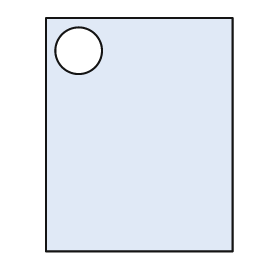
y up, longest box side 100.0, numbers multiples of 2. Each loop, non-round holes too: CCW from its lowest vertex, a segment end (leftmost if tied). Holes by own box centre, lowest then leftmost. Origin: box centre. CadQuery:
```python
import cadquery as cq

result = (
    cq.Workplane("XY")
    .moveTo(-40.0, -50.0)
    .lineTo(40.0, -50.0)
    .lineTo(40.0, 50.0)
    .lineTo(-40.0, 50.0)
    .close()
    .moveTo(-26.0, 36.0)
    .circle(10.0)
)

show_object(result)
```